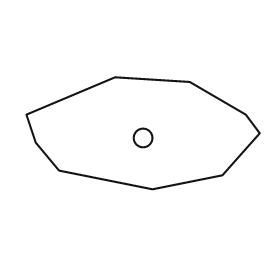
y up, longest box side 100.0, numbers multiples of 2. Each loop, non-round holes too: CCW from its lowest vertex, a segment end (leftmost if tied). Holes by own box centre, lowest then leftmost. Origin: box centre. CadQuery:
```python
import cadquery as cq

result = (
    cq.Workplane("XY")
    .moveTo(4.0, -24.0)
    .lineTo(34.0, -18.0)
    .lineTo(50.0, 0.0)
    .lineTo(44.0, 8.0)
    .lineTo(20.0, 22.0)
    .lineTo(-12.0, 24.0)
    .lineTo(-50.0, 8.0)
    .lineTo(-46.0, -4.0)
    .lineTo(-36.0, -16.0)
    .close()
    .moveTo(0.0, -2.0)
    .circle(4.0)
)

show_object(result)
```